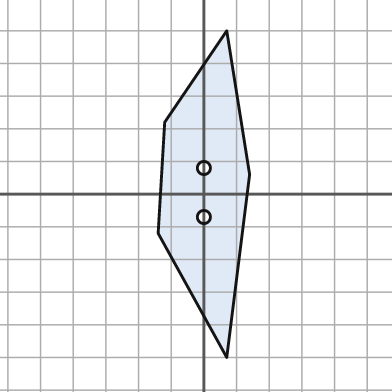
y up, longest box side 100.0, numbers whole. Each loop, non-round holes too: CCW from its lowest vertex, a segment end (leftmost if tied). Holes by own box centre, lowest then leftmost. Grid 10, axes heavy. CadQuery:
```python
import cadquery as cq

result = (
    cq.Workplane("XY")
    .moveTo(7.0, -50.0)
    .lineTo(14.0, 6.0)
    .lineTo(7.0, 50.0)
    .lineTo(-12.0, 22.0)
    .lineTo(-14.0, -12.0)
    .close()
    .moveTo(0.0, -7.0)
    .circle(2.0)
    .moveTo(0.0, 8.0)
    .circle(2.0)
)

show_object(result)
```